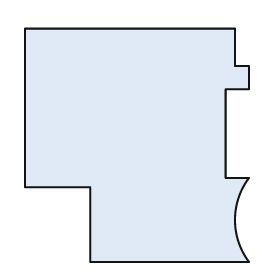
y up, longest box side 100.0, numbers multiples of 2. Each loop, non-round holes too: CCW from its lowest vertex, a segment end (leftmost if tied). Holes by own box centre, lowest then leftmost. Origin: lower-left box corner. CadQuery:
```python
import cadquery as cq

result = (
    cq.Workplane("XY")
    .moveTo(28.0, 0.0)
    .lineTo(96.0, 0.0)
    .threePointArc((90.0, 18.0), (96.0, 36.0))
    .lineTo(86.0, 36.0)
    .lineTo(86.0, 74.0)
    .lineTo(96.0, 74.0)
    .lineTo(96.0, 84.0)
    .lineTo(90.0, 84.0)
    .lineTo(90.0, 100.0)
    .lineTo(0.0, 100.0)
    .lineTo(0.0, 32.0)
    .lineTo(28.0, 32.0)
    .close()
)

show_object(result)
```